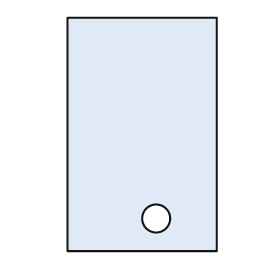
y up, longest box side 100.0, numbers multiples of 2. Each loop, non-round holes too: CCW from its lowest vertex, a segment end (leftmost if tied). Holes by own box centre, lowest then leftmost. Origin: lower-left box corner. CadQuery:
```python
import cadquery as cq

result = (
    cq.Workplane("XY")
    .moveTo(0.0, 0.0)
    .lineTo(64.0, 0.0)
    .lineTo(64.0, 100.0)
    .lineTo(0.0, 100.0)
    .close()
    .moveTo(38.0, 14.0)
    .circle(6.0)
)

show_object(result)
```